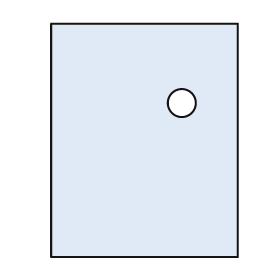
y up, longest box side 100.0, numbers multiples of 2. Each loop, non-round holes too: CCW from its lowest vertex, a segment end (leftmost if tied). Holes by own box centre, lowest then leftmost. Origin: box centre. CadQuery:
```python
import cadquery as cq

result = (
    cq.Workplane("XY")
    .moveTo(-40.0, -50.0)
    .lineTo(40.0, -50.0)
    .lineTo(40.0, 50.0)
    .lineTo(-40.0, 50.0)
    .close()
    .moveTo(16.0, 16.0)
    .circle(6.0)
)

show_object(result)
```